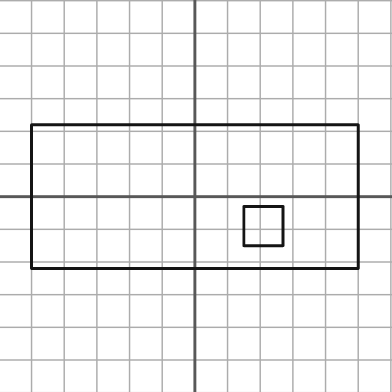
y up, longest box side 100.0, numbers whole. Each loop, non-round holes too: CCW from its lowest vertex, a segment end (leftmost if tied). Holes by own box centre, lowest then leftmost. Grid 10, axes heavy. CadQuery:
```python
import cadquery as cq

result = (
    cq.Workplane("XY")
    .moveTo(-50.0, -22.0)
    .lineTo(50.0, -22.0)
    .lineTo(50.0, 22.0)
    .lineTo(-50.0, 22.0)
    .close()
    .moveTo(15.0, -15.0)
    .lineTo(27.0, -15.0)
    .lineTo(27.0, -3.0)
    .lineTo(15.0, -3.0)
    .close()
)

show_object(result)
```